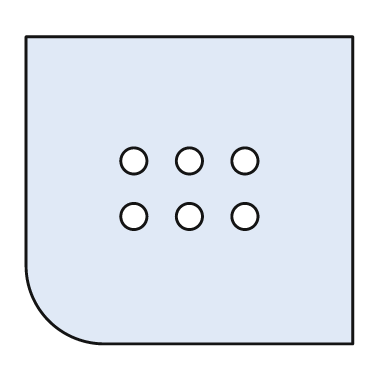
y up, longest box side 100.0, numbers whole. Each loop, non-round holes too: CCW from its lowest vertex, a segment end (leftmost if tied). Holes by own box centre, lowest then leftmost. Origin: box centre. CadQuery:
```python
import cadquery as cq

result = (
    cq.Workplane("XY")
    .moveTo(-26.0, -47.0)
    .lineTo(50.0, -47.0)
    .lineTo(50.0, 47.0)
    .lineTo(-50.0, 47.0)
    .lineTo(-50.0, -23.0)
    .threePointArc((-43.0, -40.0), (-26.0, -47.0))
    .close()
    .moveTo(-17.0, -8.0)
    .circle(4.0)
    .moveTo(0.0, -8.0)
    .circle(4.0)
    .moveTo(17.0, -8.0)
    .circle(4.0)
    .moveTo(-17.0, 9.0)
    .circle(4.0)
    .moveTo(0.0, 9.0)
    .circle(4.0)
    .moveTo(17.0, 9.0)
    .circle(4.0)
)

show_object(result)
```